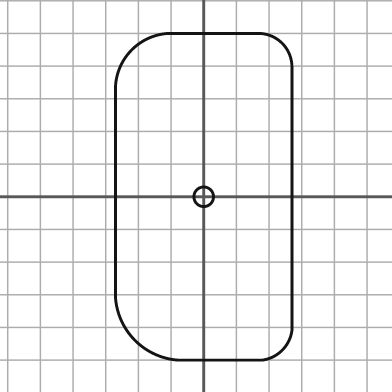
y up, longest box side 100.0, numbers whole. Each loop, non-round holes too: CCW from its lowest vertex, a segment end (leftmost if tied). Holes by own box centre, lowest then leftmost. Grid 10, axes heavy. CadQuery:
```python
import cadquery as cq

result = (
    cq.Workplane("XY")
    .moveTo(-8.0, -50.0)
    .lineTo(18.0, -50.0)
    .threePointArc((24.0, -47.0), (27.0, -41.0))
    .lineTo(27.0, 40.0)
    .threePointArc((24.0, 47.0), (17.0, 50.0))
    .lineTo(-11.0, 50.0)
    .threePointArc((-22.0, 45.0), (-27.0, 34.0))
    .lineTo(-27.0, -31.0)
    .threePointArc((-21.0, -44.0), (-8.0, -50.0))
    .close()
    .moveTo(0.0, 0.0)
    .circle(3.0)
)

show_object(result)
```